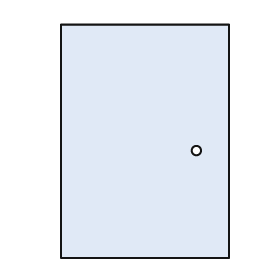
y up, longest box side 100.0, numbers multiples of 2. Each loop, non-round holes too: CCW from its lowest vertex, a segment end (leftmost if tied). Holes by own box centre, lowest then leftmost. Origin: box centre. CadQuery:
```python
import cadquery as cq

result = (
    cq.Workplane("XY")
    .moveTo(-36.0, -50.0)
    .lineTo(36.0, -50.0)
    .lineTo(36.0, 50.0)
    .lineTo(-36.0, 50.0)
    .close()
    .moveTo(22.0, -4.0)
    .circle(2.0)
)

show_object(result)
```